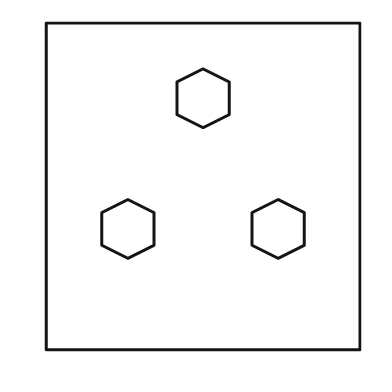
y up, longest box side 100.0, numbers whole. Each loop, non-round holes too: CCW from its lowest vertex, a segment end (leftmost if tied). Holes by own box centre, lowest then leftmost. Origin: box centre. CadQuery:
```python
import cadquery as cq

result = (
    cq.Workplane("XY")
    .moveTo(-48.0, -50.0)
    .lineTo(48.0, -50.0)
    .lineTo(48.0, 50.0)
    .lineTo(-48.0, 50.0)
    .close()
    .moveTo(-23.0, -22.0)
    .lineTo(-15.0, -18.0)
    .lineTo(-15.0, -8.0)
    .lineTo(-23.0, -4.0)
    .lineTo(-31.0, -8.0)
    .lineTo(-31.0, -18.0)
    .close()
    .moveTo(23.0, -22.0)
    .lineTo(31.0, -18.0)
    .lineTo(31.0, -8.0)
    .lineTo(23.0, -4.0)
    .lineTo(15.0, -8.0)
    .lineTo(15.0, -18.0)
    .close()
    .moveTo(0.0, 18.0)
    .lineTo(8.0, 22.0)
    .lineTo(8.0, 32.0)
    .lineTo(0.0, 36.0)
    .lineTo(-8.0, 32.0)
    .lineTo(-8.0, 22.0)
    .close()
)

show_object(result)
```